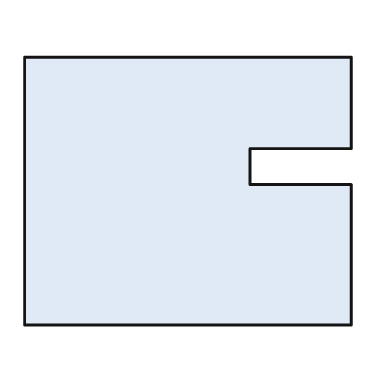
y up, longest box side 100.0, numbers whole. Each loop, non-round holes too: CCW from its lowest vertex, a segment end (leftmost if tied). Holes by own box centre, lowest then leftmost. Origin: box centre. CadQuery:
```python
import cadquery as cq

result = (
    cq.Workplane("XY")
    .moveTo(-50.0, -41.0)
    .lineTo(50.0, -41.0)
    .lineTo(50.0, 2.0)
    .lineTo(19.0, 2.0)
    .lineTo(19.0, 13.0)
    .lineTo(50.0, 13.0)
    .lineTo(50.0, 41.0)
    .lineTo(-50.0, 41.0)
    .close()
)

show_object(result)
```